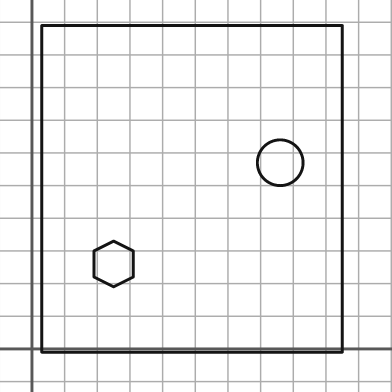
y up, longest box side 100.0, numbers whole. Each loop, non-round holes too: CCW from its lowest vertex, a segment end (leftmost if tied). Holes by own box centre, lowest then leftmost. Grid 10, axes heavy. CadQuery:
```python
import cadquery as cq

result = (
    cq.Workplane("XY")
    .moveTo(3.0, -1.0)
    .lineTo(95.0, -1.0)
    .lineTo(95.0, 99.0)
    .lineTo(3.0, 99.0)
    .close()
    .moveTo(25.0, 19.0)
    .lineTo(31.0, 22.0)
    .lineTo(31.0, 30.0)
    .lineTo(25.0, 33.0)
    .lineTo(19.0, 30.0)
    .lineTo(19.0, 22.0)
    .close()
    .moveTo(76.0, 57.0)
    .circle(7.0)
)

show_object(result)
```